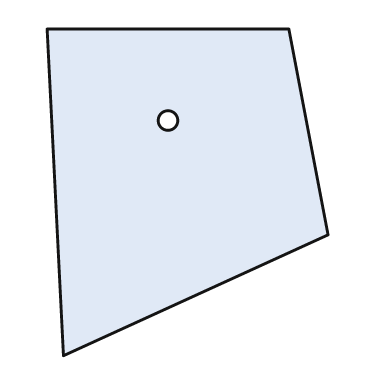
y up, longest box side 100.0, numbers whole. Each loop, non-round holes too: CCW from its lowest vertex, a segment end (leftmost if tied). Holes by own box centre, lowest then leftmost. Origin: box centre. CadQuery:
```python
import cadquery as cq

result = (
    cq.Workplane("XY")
    .moveTo(-38.0, -50.0)
    .lineTo(43.0, -13.0)
    .lineTo(31.0, 50.0)
    .lineTo(-43.0, 50.0)
    .close()
    .moveTo(-6.0, 22.0)
    .circle(3.0)
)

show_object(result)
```